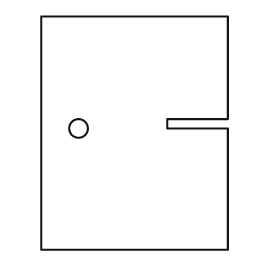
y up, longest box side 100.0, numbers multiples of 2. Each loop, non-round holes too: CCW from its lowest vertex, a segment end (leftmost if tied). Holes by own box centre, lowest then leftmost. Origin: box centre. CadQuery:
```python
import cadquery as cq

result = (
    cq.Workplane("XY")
    .moveTo(-40.0, -50.0)
    .lineTo(40.0, -50.0)
    .lineTo(40.0, 2.0)
    .lineTo(14.0, 2.0)
    .lineTo(14.0, 6.0)
    .lineTo(40.0, 6.0)
    .lineTo(40.0, 50.0)
    .lineTo(-40.0, 50.0)
    .close()
    .moveTo(-24.0, 2.0)
    .circle(4.0)
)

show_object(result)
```